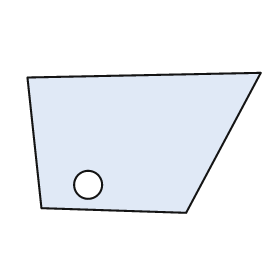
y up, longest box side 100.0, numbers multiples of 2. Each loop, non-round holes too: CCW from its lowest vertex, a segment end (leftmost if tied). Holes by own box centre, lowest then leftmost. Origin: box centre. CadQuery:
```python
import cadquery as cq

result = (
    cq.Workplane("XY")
    .moveTo(18.0, -30.0)
    .lineTo(50.0, 30.0)
    .lineTo(-50.0, 28.0)
    .lineTo(-44.0, -28.0)
    .close()
    .moveTo(-24.0, -18.0)
    .circle(6.0)
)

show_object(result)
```